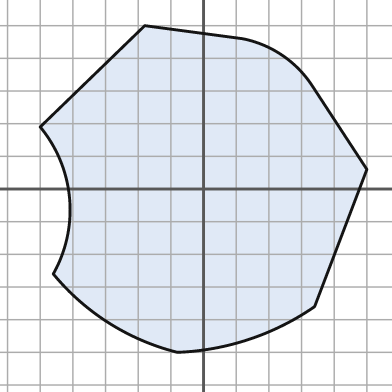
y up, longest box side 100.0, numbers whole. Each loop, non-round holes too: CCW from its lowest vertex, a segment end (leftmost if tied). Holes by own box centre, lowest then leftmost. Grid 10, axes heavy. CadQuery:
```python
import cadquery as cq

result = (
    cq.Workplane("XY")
    .moveTo(-8.0, -50.0)
    .threePointArc((14.0, -46.0), (34.0, -36.0))
    .lineTo(50.0, 6.0)
    .lineTo(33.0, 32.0)
    .threePointArc((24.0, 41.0), (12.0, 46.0))
    .lineTo(-18.0, 50.0)
    .lineTo(-50.0, 19.0)
    .threePointArc((-41.0, -3.0), (-46.0, -26.0))
    .threePointArc((-29.0, -41.0), (-8.0, -50.0))
    .close()
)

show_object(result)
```